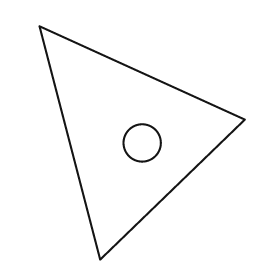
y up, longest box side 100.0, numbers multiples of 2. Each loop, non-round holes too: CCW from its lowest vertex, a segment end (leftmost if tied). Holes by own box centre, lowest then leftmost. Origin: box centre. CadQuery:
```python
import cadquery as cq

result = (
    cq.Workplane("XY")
    .moveTo(-18.0, -50.0)
    .lineTo(44.0, 10.0)
    .lineTo(-44.0, 50.0)
    .close()
    .moveTo(0.0, 0.0)
    .circle(8.0)
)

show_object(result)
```